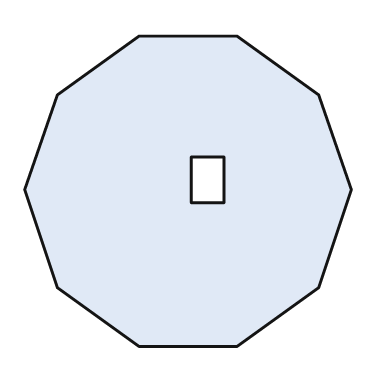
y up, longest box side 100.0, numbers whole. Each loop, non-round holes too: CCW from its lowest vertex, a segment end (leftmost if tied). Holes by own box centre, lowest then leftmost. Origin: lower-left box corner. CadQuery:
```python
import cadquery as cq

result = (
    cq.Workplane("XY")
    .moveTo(35.0, 0.0)
    .lineTo(65.0, 0.0)
    .lineTo(90.0, 18.0)
    .lineTo(100.0, 48.0)
    .lineTo(90.0, 77.0)
    .lineTo(65.0, 95.0)
    .lineTo(35.0, 95.0)
    .lineTo(10.0, 77.0)
    .lineTo(0.0, 48.0)
    .lineTo(10.0, 18.0)
    .close()
    .moveTo(51.0, 44.0)
    .lineTo(61.0, 44.0)
    .lineTo(61.0, 58.0)
    .lineTo(51.0, 58.0)
    .close()
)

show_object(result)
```